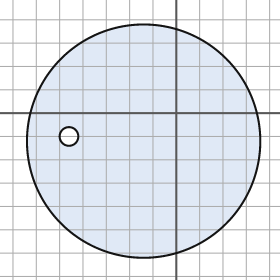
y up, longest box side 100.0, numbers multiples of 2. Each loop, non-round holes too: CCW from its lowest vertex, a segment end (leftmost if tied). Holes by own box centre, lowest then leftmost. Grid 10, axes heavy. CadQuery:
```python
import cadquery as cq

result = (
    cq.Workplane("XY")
    .moveTo(-14.0, -12.0)
    .circle(50.0)
    .moveTo(-46.0, -10.0)
    .circle(4.0)
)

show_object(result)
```